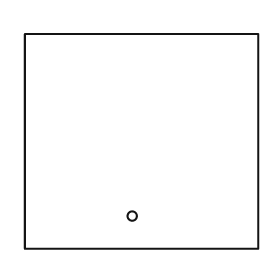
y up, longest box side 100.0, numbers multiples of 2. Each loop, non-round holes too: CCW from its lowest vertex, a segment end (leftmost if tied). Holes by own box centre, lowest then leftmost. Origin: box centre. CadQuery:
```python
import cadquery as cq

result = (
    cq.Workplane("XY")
    .moveTo(-50.0, -46.0)
    .lineTo(50.0, -46.0)
    .lineTo(50.0, 46.0)
    .lineTo(-50.0, 46.0)
    .close()
    .moveTo(-4.0, -32.0)
    .circle(2.0)
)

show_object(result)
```